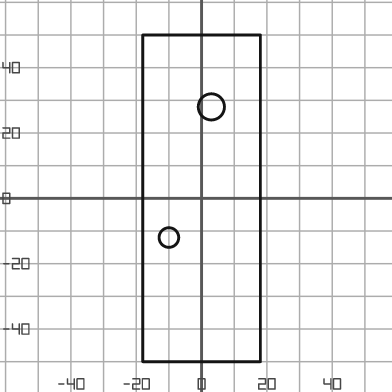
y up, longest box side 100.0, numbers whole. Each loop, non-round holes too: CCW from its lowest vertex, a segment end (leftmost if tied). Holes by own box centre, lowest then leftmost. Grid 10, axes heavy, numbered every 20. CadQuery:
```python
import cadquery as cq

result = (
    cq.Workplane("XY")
    .moveTo(-18.0, -50.0)
    .lineTo(18.0, -50.0)
    .lineTo(18.0, 50.0)
    .lineTo(-18.0, 50.0)
    .close()
    .moveTo(-10.0, -12.0)
    .circle(3.0)
    .moveTo(3.0, 28.0)
    .circle(4.0)
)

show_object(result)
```